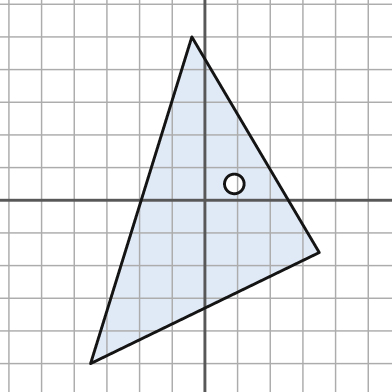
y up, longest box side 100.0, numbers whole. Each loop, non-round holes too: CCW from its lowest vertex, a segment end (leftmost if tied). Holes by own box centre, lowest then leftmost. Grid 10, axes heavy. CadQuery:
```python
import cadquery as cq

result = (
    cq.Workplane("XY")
    .moveTo(-35.0, -50.0)
    .lineTo(35.0, -16.0)
    .lineTo(-4.0, 50.0)
    .close()
    .moveTo(9.0, 5.0)
    .circle(3.0)
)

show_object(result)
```